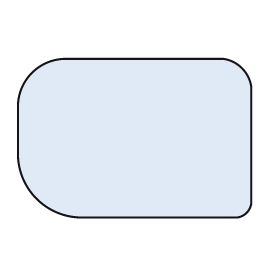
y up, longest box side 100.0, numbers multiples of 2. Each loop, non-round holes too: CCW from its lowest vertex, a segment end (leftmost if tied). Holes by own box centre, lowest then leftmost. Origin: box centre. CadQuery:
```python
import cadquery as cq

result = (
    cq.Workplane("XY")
    .moveTo(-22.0, -34.0)
    .lineTo(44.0, -34.0)
    .threePointArc((48.0, -32.0), (50.0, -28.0))
    .lineTo(50.0, 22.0)
    .threePointArc((46.0, 30.0), (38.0, 34.0))
    .lineTo(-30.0, 34.0)
    .threePointArc((-44.0, 28.0), (-50.0, 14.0))
    .lineTo(-50.0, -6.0)
    .threePointArc((-42.0, -26.0), (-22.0, -34.0))
    .close()
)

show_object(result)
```